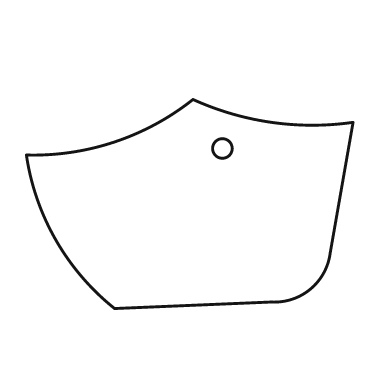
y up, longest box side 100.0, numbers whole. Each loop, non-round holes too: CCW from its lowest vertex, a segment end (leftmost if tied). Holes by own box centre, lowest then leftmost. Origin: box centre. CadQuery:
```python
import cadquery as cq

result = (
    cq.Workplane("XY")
    .moveTo(-23.0, -32.0)
    .lineTo(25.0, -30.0)
    .threePointArc((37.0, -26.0), (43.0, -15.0))
    .lineTo(50.0, 25.0)
    .threePointArc((25.0, 25.0), (1.0, 32.0))
    .threePointArc((-23.0, 19.0), (-50.0, 15.0))
    .threePointArc((-41.0, -11.0), (-23.0, -32.0))
    .close()
    .moveTo(10.0, 17.0)
    .circle(3.0)
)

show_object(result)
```